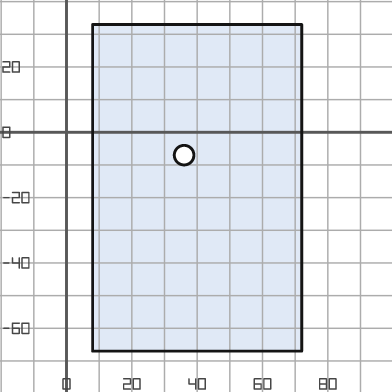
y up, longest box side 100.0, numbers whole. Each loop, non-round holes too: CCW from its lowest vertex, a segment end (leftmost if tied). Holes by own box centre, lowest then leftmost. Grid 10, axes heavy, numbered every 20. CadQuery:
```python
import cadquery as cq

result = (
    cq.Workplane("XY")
    .moveTo(8.0, -67.0)
    .lineTo(72.0, -67.0)
    .lineTo(72.0, 33.0)
    .lineTo(8.0, 33.0)
    .close()
    .moveTo(36.0, -7.0)
    .circle(3.0)
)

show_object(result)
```